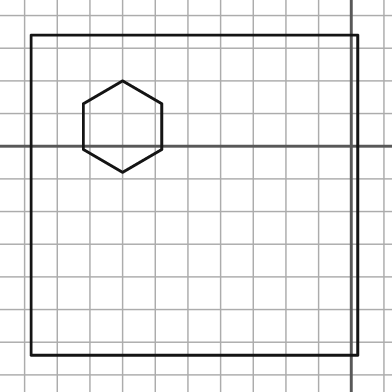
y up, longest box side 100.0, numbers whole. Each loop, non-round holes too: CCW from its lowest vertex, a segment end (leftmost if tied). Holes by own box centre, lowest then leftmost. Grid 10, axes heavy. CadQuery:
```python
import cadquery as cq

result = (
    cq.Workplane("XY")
    .moveTo(-98.0, -64.0)
    .lineTo(2.0, -64.0)
    .lineTo(2.0, 34.0)
    .lineTo(-98.0, 34.0)
    .close()
    .moveTo(-70.0, -8.0)
    .lineTo(-58.0, -1.0)
    .lineTo(-58.0, 13.0)
    .lineTo(-70.0, 20.0)
    .lineTo(-82.0, 13.0)
    .lineTo(-82.0, -1.0)
    .close()
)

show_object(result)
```